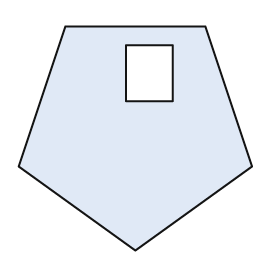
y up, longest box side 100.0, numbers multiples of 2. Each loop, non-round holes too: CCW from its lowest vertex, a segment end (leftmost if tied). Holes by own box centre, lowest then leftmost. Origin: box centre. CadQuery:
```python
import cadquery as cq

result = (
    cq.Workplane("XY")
    .moveTo(0.0, -48.0)
    .lineTo(50.0, -12.0)
    .lineTo(30.0, 48.0)
    .lineTo(-30.0, 48.0)
    .lineTo(-50.0, -12.0)
    .close()
    .moveTo(-4.0, 16.0)
    .lineTo(16.0, 16.0)
    .lineTo(16.0, 40.0)
    .lineTo(-4.0, 40.0)
    .close()
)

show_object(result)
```